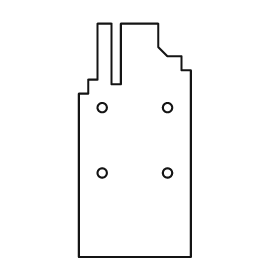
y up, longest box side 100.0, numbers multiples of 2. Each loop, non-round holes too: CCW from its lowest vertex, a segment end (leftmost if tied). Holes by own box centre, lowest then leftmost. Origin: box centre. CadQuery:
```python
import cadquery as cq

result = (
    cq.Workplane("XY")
    .moveTo(-24.0, -50.0)
    .lineTo(24.0, -50.0)
    .lineTo(24.0, 30.0)
    .lineTo(20.0, 30.0)
    .lineTo(20.0, 36.0)
    .lineTo(14.0, 36.0)
    .lineTo(10.0, 40.0)
    .lineTo(10.0, 50.0)
    .lineTo(-6.0, 50.0)
    .lineTo(-6.0, 24.0)
    .lineTo(-10.0, 24.0)
    .lineTo(-10.0, 50.0)
    .lineTo(-16.0, 50.0)
    .lineTo(-16.0, 26.0)
    .lineTo(-20.0, 26.0)
    .lineTo(-20.0, 20.0)
    .lineTo(-24.0, 20.0)
    .close()
    .moveTo(-14.0, -14.0)
    .circle(2.0)
    .moveTo(14.0, -14.0)
    .circle(2.0)
    .moveTo(-14.0, 14.0)
    .circle(2.0)
    .moveTo(14.0, 14.0)
    .circle(2.0)
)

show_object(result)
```